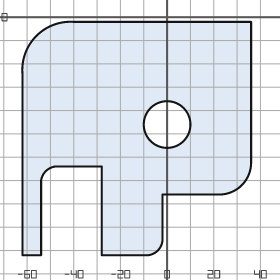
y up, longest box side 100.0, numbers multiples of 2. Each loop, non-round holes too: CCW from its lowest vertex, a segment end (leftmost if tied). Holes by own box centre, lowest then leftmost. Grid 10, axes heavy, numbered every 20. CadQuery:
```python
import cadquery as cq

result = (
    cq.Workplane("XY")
    .moveTo(-62.0, -102.0)
    .lineTo(-54.0, -102.0)
    .lineTo(-54.0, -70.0)
    .threePointArc((-52.0, -66.0), (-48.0, -64.0))
    .lineTo(-28.0, -64.0)
    .lineTo(-28.0, -102.0)
    .lineTo(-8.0, -102.0)
    .threePointArc((-4.0, -100.0), (-2.0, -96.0))
    .lineTo(-2.0, -76.0)
    .lineTo(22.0, -76.0)
    .threePointArc((32.0, -72.0), (36.0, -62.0))
    .lineTo(36.0, -2.0)
    .lineTo(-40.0, -2.0)
    .threePointArc((-56.0, -8.0), (-62.0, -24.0))
    .close()
    .moveTo(0.0, -46.0)
    .circle(10.0)
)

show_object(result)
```